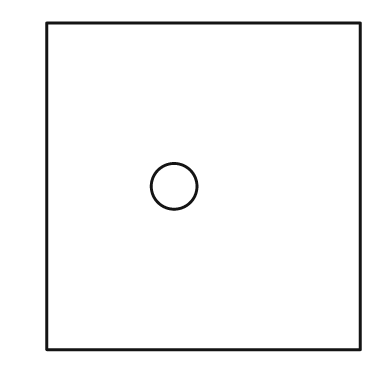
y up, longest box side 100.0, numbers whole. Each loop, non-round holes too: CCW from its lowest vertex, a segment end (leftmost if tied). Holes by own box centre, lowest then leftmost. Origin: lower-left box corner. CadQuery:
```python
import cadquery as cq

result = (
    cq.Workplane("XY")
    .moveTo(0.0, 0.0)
    .lineTo(96.0, 0.0)
    .lineTo(96.0, 100.0)
    .lineTo(0.0, 100.0)
    .close()
    .moveTo(39.0, 50.0)
    .circle(7.0)
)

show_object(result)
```